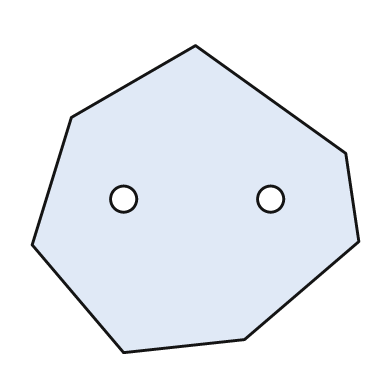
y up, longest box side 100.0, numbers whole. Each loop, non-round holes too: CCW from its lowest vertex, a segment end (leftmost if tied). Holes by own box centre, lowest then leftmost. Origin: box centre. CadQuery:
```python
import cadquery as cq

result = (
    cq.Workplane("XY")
    .moveTo(-22.0, -47.0)
    .lineTo(15.0, -43.0)
    .lineTo(50.0, -13.0)
    .lineTo(46.0, 14.0)
    .lineTo(0.0, 47.0)
    .lineTo(-38.0, 25.0)
    .lineTo(-50.0, -14.0)
    .close()
    .moveTo(-22.0, 0.0)
    .circle(4.0)
    .moveTo(23.0, 0.0)
    .circle(4.0)
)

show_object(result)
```